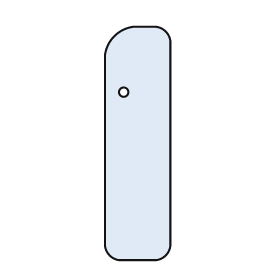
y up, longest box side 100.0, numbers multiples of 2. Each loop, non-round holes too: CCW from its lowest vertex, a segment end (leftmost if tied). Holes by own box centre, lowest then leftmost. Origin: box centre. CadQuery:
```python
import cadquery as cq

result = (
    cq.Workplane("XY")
    .moveTo(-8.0, -50.0)
    .lineTo(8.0, -50.0)
    .threePointArc((12.0, -48.0), (14.0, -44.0))
    .lineTo(14.0, 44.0)
    .threePointArc((12.0, 48.0), (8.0, 50.0))
    .lineTo(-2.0, 50.0)
    .threePointArc((-10.0, 46.0), (-14.0, 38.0))
    .lineTo(-14.0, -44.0)
    .threePointArc((-12.0, -48.0), (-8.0, -50.0))
    .close()
    .moveTo(-6.0, 22.0)
    .circle(2.0)
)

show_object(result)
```